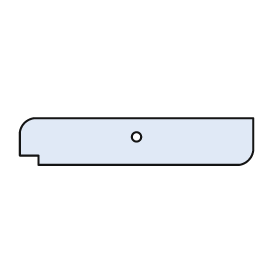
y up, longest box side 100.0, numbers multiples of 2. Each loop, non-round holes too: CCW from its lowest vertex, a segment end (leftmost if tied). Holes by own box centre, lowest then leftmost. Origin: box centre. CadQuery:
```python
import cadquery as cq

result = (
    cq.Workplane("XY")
    .moveTo(-42.0, -10.0)
    .lineTo(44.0, -10.0)
    .threePointArc((48.0, -8.0), (50.0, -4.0))
    .lineTo(50.0, 10.0)
    .lineTo(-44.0, 10.0)
    .threePointArc((-48.0, 8.0), (-50.0, 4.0))
    .lineTo(-50.0, -6.0)
    .lineTo(-42.0, -6.0)
    .close()
    .moveTo(0.0, 2.0)
    .circle(2.0)
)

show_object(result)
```